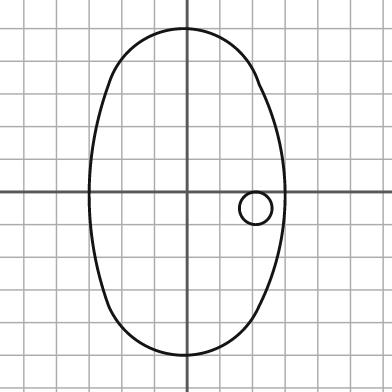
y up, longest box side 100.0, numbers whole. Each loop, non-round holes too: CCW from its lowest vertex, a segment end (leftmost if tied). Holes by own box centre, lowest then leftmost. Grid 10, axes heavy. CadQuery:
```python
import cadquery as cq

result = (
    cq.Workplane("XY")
    .moveTo(-24.0, -35.0)
    .threePointArc((-1.0, -50.0), (22.0, -35.0))
    .threePointArc((30.0, -1.0), (22.0, 33.0))
    .threePointArc((-1.0, 50.0), (-24.0, 33.0))
    .threePointArc((-30.0, -1.0), (-24.0, -35.0))
    .close()
    .moveTo(21.0, -5.0)
    .circle(5.0)
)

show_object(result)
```